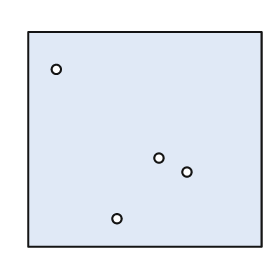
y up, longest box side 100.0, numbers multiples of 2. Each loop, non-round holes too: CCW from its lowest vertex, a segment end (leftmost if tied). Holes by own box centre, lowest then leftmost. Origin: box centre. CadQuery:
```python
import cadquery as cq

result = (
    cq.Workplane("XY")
    .moveTo(-50.0, -46.0)
    .lineTo(50.0, -46.0)
    .lineTo(50.0, 46.0)
    .lineTo(-50.0, 46.0)
    .close()
    .moveTo(-12.0, -34.0)
    .circle(2.0)
    .moveTo(18.0, -14.0)
    .circle(2.0)
    .moveTo(6.0, -8.0)
    .circle(2.0)
    .moveTo(-38.0, 30.0)
    .circle(2.0)
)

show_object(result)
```